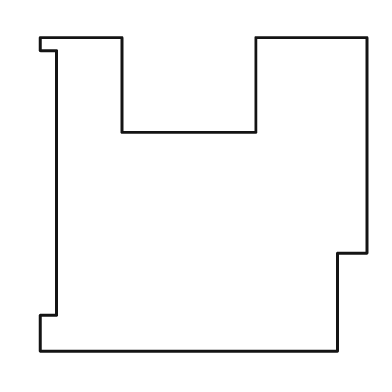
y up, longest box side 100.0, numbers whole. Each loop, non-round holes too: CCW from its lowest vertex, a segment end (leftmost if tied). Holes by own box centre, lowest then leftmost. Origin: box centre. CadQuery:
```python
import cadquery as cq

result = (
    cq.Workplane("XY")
    .moveTo(-50.0, -48.0)
    .lineTo(41.0, -48.0)
    .lineTo(41.0, -18.0)
    .lineTo(50.0, -18.0)
    .lineTo(50.0, 48.0)
    .lineTo(16.0, 48.0)
    .lineTo(16.0, 19.0)
    .lineTo(-25.0, 19.0)
    .lineTo(-25.0, 48.0)
    .lineTo(-50.0, 48.0)
    .lineTo(-50.0, 44.0)
    .lineTo(-45.0, 44.0)
    .lineTo(-45.0, -37.0)
    .lineTo(-50.0, -37.0)
    .close()
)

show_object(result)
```